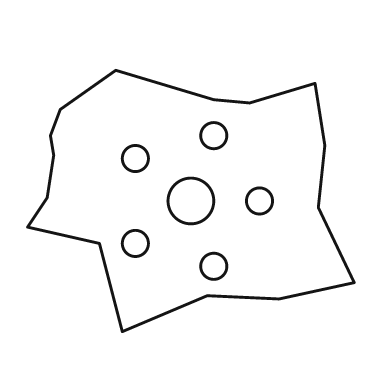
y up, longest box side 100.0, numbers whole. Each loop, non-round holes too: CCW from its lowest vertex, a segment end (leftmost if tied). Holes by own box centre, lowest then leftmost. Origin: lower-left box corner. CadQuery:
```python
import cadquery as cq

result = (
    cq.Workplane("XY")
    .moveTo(29.0, 0.0)
    .lineTo(55.0, 11.0)
    .lineTo(77.0, 10.0)
    .lineTo(100.0, 15.0)
    .lineTo(89.0, 38.0)
    .lineTo(91.0, 57.0)
    .lineTo(88.0, 76.0)
    .lineTo(68.0, 70.0)
    .lineTo(57.0, 71.0)
    .lineTo(27.0, 80.0)
    .lineTo(10.0, 68.0)
    .lineTo(7.0, 60.0)
    .lineTo(8.0, 54.0)
    .lineTo(6.0, 41.0)
    .lineTo(0.0, 32.0)
    .lineTo(22.0, 27.0)
    .close()
    .moveTo(57.0, 20.0)
    .circle(4.0)
    .moveTo(33.0, 27.0)
    .circle(4.0)
    .moveTo(50.0, 40.0)
    .circle(7.0)
    .moveTo(71.0, 40.0)
    .circle(4.0)
    .moveTo(33.0, 53.0)
    .circle(4.0)
    .moveTo(57.0, 60.0)
    .circle(4.0)
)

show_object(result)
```